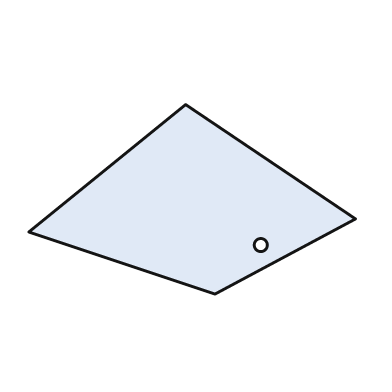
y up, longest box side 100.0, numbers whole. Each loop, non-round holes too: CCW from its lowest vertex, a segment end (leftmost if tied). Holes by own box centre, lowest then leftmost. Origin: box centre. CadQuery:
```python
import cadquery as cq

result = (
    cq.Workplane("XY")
    .moveTo(7.0, -29.0)
    .lineTo(50.0, -6.0)
    .lineTo(-2.0, 29.0)
    .lineTo(-50.0, -10.0)
    .close()
    .moveTo(21.0, -14.0)
    .circle(2.0)
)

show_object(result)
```